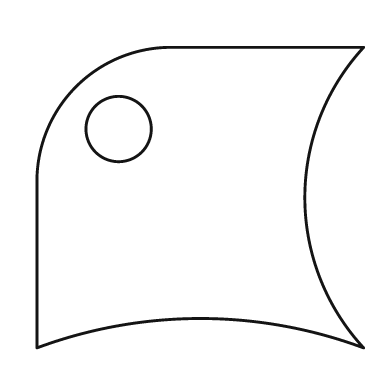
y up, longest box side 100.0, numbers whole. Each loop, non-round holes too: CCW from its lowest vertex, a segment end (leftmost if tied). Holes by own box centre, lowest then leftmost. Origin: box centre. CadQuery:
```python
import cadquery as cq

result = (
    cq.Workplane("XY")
    .moveTo(-50.0, -46.0)
    .threePointArc((0.0, -37.0), (50.0, -46.0))
    .threePointArc((32.0, 0.0), (50.0, 46.0))
    .lineTo(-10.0, 46.0)
    .threePointArc((-38.0, 34.0), (-50.0, 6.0))
    .close()
    .moveTo(-25.0, 21.0)
    .circle(10.0)
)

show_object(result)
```